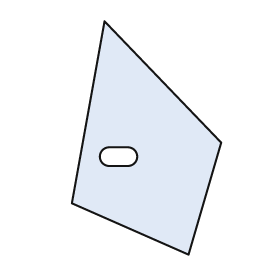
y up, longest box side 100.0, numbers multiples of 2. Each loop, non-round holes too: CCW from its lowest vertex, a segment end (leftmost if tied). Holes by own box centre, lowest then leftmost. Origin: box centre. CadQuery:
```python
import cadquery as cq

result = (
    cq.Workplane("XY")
    .moveTo(18.0, -50.0)
    .lineTo(32.0, -2.0)
    .lineTo(-18.0, 50.0)
    .lineTo(-32.0, -28.0)
    .close()
    .moveTo(-16.0, -12.0)
    .lineTo(-8.0, -12.0)
    .threePointArc((-4.0, -8.0), (-8.0, -4.0))
    .lineTo(-16.0, -4.0)
    .threePointArc((-20.0, -8.0), (-16.0, -12.0))
    .close()
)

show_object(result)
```